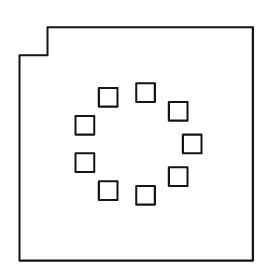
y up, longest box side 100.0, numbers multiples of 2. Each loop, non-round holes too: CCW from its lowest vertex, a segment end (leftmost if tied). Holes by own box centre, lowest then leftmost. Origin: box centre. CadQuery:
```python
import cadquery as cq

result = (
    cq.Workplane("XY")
    .moveTo(-50.0, -50.0)
    .lineTo(50.0, -50.0)
    .lineTo(50.0, 50.0)
    .lineTo(-38.0, 50.0)
    .lineTo(-38.0, 38.0)
    .lineTo(-50.0, 38.0)
    .close()
    .moveTo(0.0, -26.0)
    .lineTo(8.0, -26.0)
    .lineTo(8.0, -18.0)
    .lineTo(0.0, -18.0)
    .close()
    .moveTo(-16.0, -24.0)
    .lineTo(-8.0, -24.0)
    .lineTo(-8.0, -16.0)
    .lineTo(-16.0, -16.0)
    .close()
    .moveTo(14.0, -18.0)
    .lineTo(22.0, -18.0)
    .lineTo(22.0, -10.0)
    .lineTo(14.0, -10.0)
    .close()
    .moveTo(-26.0, -12.0)
    .lineTo(-18.0, -12.0)
    .lineTo(-18.0, -4.0)
    .lineTo(-26.0, -4.0)
    .close()
    .moveTo(20.0, -4.0)
    .lineTo(28.0, -4.0)
    .lineTo(28.0, 4.0)
    .lineTo(20.0, 4.0)
    .close()
    .moveTo(-26.0, 4.0)
    .lineTo(-18.0, 4.0)
    .lineTo(-18.0, 12.0)
    .lineTo(-26.0, 12.0)
    .close()
    .moveTo(14.0, 10.0)
    .lineTo(22.0, 10.0)
    .lineTo(22.0, 18.0)
    .lineTo(14.0, 18.0)
    .close()
    .moveTo(-16.0, 16.0)
    .lineTo(-8.0, 16.0)
    .lineTo(-8.0, 24.0)
    .lineTo(-16.0, 24.0)
    .close()
    .moveTo(0.0, 18.0)
    .lineTo(8.0, 18.0)
    .lineTo(8.0, 26.0)
    .lineTo(0.0, 26.0)
    .close()
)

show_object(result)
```